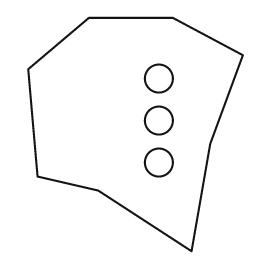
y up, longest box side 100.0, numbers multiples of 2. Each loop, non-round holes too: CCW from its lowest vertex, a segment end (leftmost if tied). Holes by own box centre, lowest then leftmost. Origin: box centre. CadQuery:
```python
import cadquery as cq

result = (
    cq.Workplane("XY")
    .moveTo(24.0, -50.0)
    .lineTo(32.0, -4.0)
    .lineTo(46.0, 34.0)
    .lineTo(16.0, 50.0)
    .lineTo(-20.0, 50.0)
    .lineTo(-46.0, 28.0)
    .lineTo(-42.0, -18.0)
    .lineTo(-16.0, -24.0)
    .close()
    .moveTo(10.0, -12.0)
    .circle(6.0)
    .moveTo(10.0, 6.0)
    .circle(6.0)
    .moveTo(10.0, 24.0)
    .circle(6.0)
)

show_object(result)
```